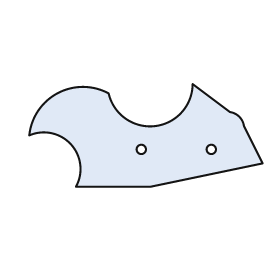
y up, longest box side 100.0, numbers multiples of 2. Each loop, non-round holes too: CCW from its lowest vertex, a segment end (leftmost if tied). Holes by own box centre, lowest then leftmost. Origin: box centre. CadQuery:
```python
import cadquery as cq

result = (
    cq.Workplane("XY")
    .moveTo(-30.0, -22.0)
    .lineTo(2.0, -22.0)
    .lineTo(50.0, -12.0)
    .lineTo(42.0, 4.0)
    .threePointArc((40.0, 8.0), (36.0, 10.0))
    .lineTo(20.0, 22.0)
    .threePointArc((4.0, 4.0), (-16.0, 18.0))
    .threePointArc((-38.0, 18.0), (-50.0, 0.0))
    .threePointArc((-32.0, -4.0), (-30.0, -22.0))
    .close()
    .moveTo(-2.0, -6.0)
    .circle(2.0)
    .moveTo(28.0, -6.0)
    .circle(2.0)
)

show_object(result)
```